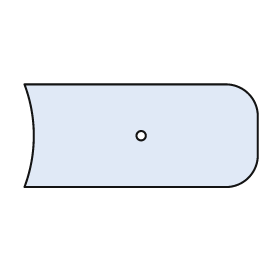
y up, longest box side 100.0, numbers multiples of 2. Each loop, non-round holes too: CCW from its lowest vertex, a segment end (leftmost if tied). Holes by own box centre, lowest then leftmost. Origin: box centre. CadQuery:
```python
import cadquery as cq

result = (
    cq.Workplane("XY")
    .moveTo(-50.0, -22.0)
    .lineTo(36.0, -22.0)
    .threePointArc((46.0, -18.0), (50.0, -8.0))
    .lineTo(50.0, 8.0)
    .threePointArc((46.0, 18.0), (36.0, 22.0))
    .lineTo(-50.0, 22.0)
    .threePointArc((-46.0, 0.0), (-50.0, -22.0))
    .close()
    .moveTo(0.0, 0.0)
    .circle(2.0)
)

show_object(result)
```